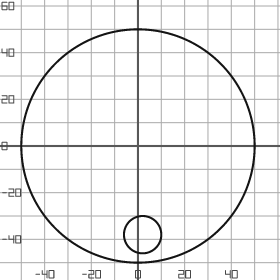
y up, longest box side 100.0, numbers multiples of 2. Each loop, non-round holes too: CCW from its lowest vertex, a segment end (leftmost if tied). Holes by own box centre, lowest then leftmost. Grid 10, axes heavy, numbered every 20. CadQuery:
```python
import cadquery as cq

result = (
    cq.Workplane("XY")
    .moveTo(0.0, 0.0)
    .circle(50.0)
    .moveTo(2.0, -38.0)
    .circle(8.0)
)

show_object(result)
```